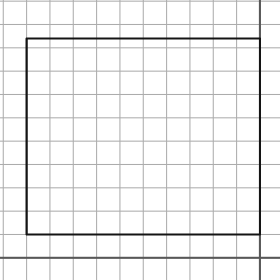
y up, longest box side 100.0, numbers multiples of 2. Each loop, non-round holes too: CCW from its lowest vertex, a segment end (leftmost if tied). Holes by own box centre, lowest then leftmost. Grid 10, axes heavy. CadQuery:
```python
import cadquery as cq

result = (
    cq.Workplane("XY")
    .moveTo(-100.0, 10.0)
    .lineTo(0.0, 10.0)
    .lineTo(0.0, 94.0)
    .lineTo(-100.0, 94.0)
    .close()
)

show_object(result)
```